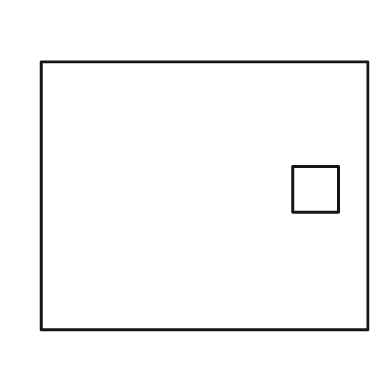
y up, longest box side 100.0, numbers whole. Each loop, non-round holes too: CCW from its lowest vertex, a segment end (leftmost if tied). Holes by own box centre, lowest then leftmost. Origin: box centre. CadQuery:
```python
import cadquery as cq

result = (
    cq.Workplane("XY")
    .moveTo(-50.0, -41.0)
    .lineTo(50.0, -41.0)
    .lineTo(50.0, 41.0)
    .lineTo(-50.0, 41.0)
    .close()
    .moveTo(27.0, -5.0)
    .lineTo(41.0, -5.0)
    .lineTo(41.0, 9.0)
    .lineTo(27.0, 9.0)
    .close()
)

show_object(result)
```